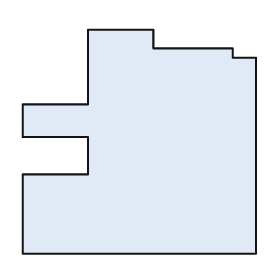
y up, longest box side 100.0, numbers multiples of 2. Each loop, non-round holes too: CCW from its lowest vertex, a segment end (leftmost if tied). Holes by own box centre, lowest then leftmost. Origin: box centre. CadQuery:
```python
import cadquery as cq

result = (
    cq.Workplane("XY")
    .moveTo(-50.0, -48.0)
    .lineTo(50.0, -48.0)
    .lineTo(50.0, 36.0)
    .lineTo(40.0, 36.0)
    .lineTo(40.0, 40.0)
    .lineTo(6.0, 40.0)
    .lineTo(6.0, 48.0)
    .lineTo(-22.0, 48.0)
    .lineTo(-22.0, 16.0)
    .lineTo(-50.0, 16.0)
    .lineTo(-50.0, 2.0)
    .lineTo(-22.0, 2.0)
    .lineTo(-22.0, -14.0)
    .lineTo(-50.0, -14.0)
    .close()
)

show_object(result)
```